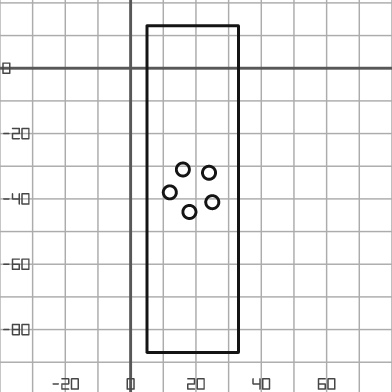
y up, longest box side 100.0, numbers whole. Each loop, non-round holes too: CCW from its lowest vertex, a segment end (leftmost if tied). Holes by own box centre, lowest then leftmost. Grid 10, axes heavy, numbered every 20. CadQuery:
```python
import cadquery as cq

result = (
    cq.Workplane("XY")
    .moveTo(5.0, -87.0)
    .lineTo(33.0, -87.0)
    .lineTo(33.0, 13.0)
    .lineTo(5.0, 13.0)
    .close()
    .moveTo(18.0, -44.0)
    .circle(2.0)
    .moveTo(25.0, -41.0)
    .circle(2.0)
    .moveTo(12.0, -38.0)
    .circle(2.0)
    .moveTo(24.0, -32.0)
    .circle(2.0)
    .moveTo(16.0, -31.0)
    .circle(2.0)
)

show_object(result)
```